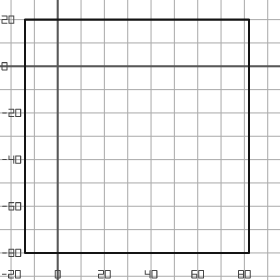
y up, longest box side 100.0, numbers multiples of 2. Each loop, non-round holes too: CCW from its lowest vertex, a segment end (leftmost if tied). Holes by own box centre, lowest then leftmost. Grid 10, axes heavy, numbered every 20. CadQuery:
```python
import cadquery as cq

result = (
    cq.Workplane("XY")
    .moveTo(-14.0, -80.0)
    .lineTo(82.0, -80.0)
    .lineTo(82.0, 20.0)
    .lineTo(-14.0, 20.0)
    .close()
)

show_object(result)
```